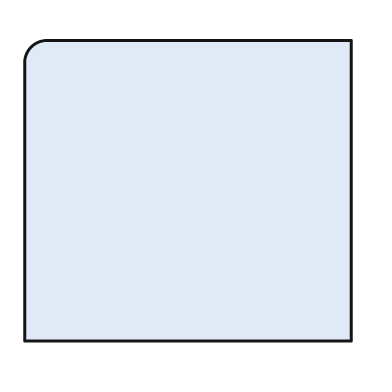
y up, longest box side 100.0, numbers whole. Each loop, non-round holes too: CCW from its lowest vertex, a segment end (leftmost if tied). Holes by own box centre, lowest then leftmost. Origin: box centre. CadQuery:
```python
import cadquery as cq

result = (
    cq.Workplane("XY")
    .moveTo(-50.0, -46.0)
    .lineTo(50.0, -46.0)
    .lineTo(50.0, 46.0)
    .lineTo(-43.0, 46.0)
    .threePointArc((-48.0, 44.0), (-50.0, 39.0))
    .close()
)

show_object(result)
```